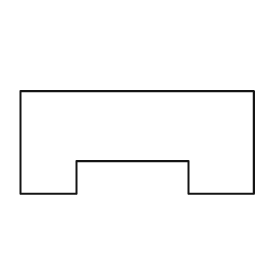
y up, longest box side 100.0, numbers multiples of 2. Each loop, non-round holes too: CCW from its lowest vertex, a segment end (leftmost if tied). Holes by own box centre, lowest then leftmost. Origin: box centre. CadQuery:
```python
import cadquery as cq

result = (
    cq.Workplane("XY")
    .moveTo(-50.0, -22.0)
    .lineTo(-26.0, -22.0)
    .lineTo(-26.0, -8.0)
    .lineTo(22.0, -8.0)
    .lineTo(22.0, -22.0)
    .lineTo(50.0, -22.0)
    .lineTo(50.0, 22.0)
    .lineTo(-50.0, 22.0)
    .close()
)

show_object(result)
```